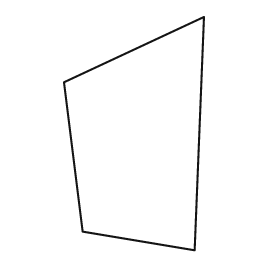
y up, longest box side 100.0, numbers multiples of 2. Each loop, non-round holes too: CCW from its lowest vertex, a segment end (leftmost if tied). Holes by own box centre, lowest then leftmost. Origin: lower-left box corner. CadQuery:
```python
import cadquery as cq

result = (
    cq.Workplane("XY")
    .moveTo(56.0, 0.0)
    .lineTo(60.0, 100.0)
    .lineTo(0.0, 72.0)
    .lineTo(8.0, 8.0)
    .close()
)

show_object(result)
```